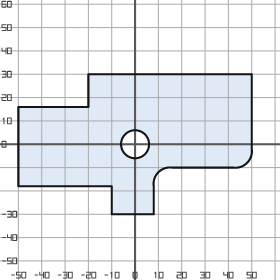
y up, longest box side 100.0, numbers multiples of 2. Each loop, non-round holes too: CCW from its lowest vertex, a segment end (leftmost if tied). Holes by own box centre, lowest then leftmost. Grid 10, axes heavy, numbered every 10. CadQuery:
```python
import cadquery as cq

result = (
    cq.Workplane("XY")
    .moveTo(-10.0, -30.0)
    .lineTo(8.0, -30.0)
    .lineTo(8.0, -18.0)
    .threePointArc((10.0, -12.0), (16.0, -10.0))
    .lineTo(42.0, -10.0)
    .threePointArc((48.0, -8.0), (50.0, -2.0))
    .lineTo(50.0, 30.0)
    .lineTo(-20.0, 30.0)
    .lineTo(-20.0, 16.0)
    .lineTo(-50.0, 16.0)
    .lineTo(-50.0, -18.0)
    .lineTo(-10.0, -18.0)
    .close()
    .moveTo(0.0, 0.0)
    .circle(6.0)
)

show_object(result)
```